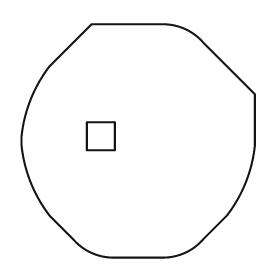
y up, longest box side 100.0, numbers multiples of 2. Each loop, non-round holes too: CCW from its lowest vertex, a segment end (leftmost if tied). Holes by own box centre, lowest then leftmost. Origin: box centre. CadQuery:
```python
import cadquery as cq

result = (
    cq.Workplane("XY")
    .moveTo(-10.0, -50.0)
    .lineTo(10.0, -50.0)
    .threePointArc((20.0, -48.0), (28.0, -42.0))
    .lineTo(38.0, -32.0)
    .threePointArc((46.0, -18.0), (50.0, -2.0))
    .lineTo(50.0, 20.0)
    .lineTo(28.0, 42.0)
    .threePointArc((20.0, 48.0), (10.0, 50.0))
    .lineTo(-20.0, 50.0)
    .lineTo(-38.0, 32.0)
    .threePointArc((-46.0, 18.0), (-50.0, 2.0))
    .lineTo(-50.0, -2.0)
    .threePointArc((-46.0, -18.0), (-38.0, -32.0))
    .lineTo(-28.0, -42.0)
    .threePointArc((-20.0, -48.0), (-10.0, -50.0))
    .close()
    .moveTo(-22.0, -4.0)
    .lineTo(-10.0, -4.0)
    .lineTo(-10.0, 8.0)
    .lineTo(-22.0, 8.0)
    .close()
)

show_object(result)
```